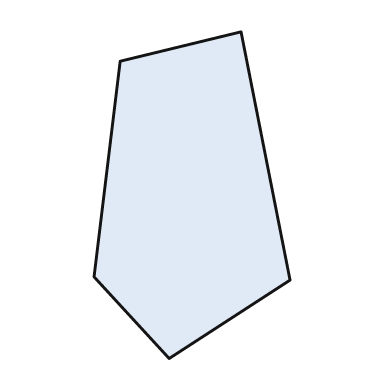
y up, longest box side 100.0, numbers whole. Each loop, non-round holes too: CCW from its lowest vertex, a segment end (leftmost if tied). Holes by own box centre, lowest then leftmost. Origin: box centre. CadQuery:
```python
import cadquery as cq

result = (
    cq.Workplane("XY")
    .moveTo(-7.0, -50.0)
    .lineTo(30.0, -26.0)
    .lineTo(15.0, 50.0)
    .lineTo(-22.0, 41.0)
    .lineTo(-30.0, -25.0)
    .close()
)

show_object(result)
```